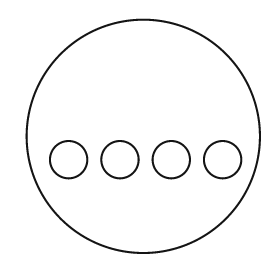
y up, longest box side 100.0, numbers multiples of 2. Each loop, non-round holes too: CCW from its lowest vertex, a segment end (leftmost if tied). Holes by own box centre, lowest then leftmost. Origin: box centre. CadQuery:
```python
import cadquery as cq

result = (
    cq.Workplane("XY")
    .moveTo(0.0, 0.0)
    .circle(50.0)
    .moveTo(-32.0, -10.0)
    .circle(8.0)
    .moveTo(-10.0, -10.0)
    .circle(8.0)
    .moveTo(12.0, -10.0)
    .circle(8.0)
    .moveTo(34.0, -10.0)
    .circle(8.0)
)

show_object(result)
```